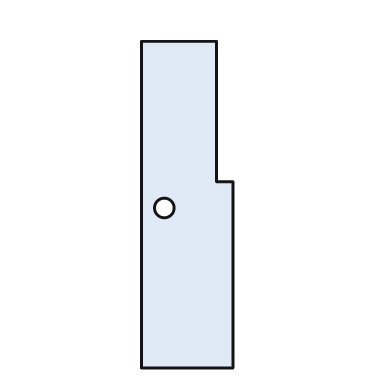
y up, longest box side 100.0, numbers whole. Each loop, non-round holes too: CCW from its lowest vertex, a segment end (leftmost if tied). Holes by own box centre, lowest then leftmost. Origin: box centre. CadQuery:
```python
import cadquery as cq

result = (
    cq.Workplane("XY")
    .moveTo(-14.0, -50.0)
    .lineTo(14.0, -50.0)
    .lineTo(14.0, 7.0)
    .lineTo(9.0, 7.0)
    .lineTo(9.0, 50.0)
    .lineTo(-14.0, 50.0)
    .close()
    .moveTo(-7.0, -1.0)
    .circle(3.0)
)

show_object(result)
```